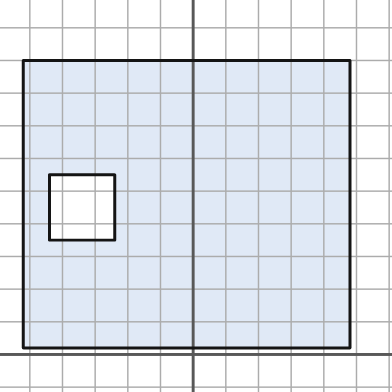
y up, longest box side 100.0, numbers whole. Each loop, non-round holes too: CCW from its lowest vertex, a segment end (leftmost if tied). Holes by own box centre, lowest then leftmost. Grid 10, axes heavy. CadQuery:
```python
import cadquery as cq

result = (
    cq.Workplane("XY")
    .moveTo(-52.0, 2.0)
    .lineTo(48.0, 2.0)
    .lineTo(48.0, 90.0)
    .lineTo(-52.0, 90.0)
    .close()
    .moveTo(-44.0, 35.0)
    .lineTo(-24.0, 35.0)
    .lineTo(-24.0, 55.0)
    .lineTo(-44.0, 55.0)
    .close()
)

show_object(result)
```